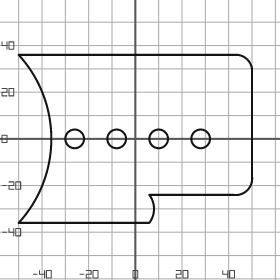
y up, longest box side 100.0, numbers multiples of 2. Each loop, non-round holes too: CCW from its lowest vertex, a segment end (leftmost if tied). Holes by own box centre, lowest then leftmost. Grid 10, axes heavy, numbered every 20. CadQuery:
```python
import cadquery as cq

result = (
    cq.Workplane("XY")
    .moveTo(-50.0, -36.0)
    .lineTo(6.0, -36.0)
    .threePointArc((8.0, -30.0), (6.0, -24.0))
    .lineTo(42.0, -24.0)
    .threePointArc((48.0, -22.0), (50.0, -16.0))
    .lineTo(50.0, 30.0)
    .threePointArc((48.0, 34.0), (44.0, 36.0))
    .lineTo(-50.0, 36.0)
    .threePointArc((-36.0, 0.0), (-50.0, -36.0))
    .close()
    .moveTo(-26.0, 0.0)
    .circle(4.0)
    .moveTo(-8.0, 0.0)
    .circle(4.0)
    .moveTo(10.0, 0.0)
    .circle(4.0)
    .moveTo(28.0, 0.0)
    .circle(4.0)
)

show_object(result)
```